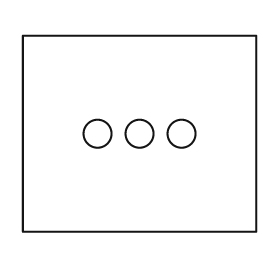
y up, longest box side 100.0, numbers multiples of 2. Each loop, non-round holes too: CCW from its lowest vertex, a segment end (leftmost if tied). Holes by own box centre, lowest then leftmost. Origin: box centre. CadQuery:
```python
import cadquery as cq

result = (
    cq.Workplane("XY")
    .moveTo(-50.0, -42.0)
    .lineTo(50.0, -42.0)
    .lineTo(50.0, 42.0)
    .lineTo(-50.0, 42.0)
    .close()
    .moveTo(-18.0, 0.0)
    .circle(6.0)
    .moveTo(0.0, 0.0)
    .circle(6.0)
    .moveTo(18.0, 0.0)
    .circle(6.0)
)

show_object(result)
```